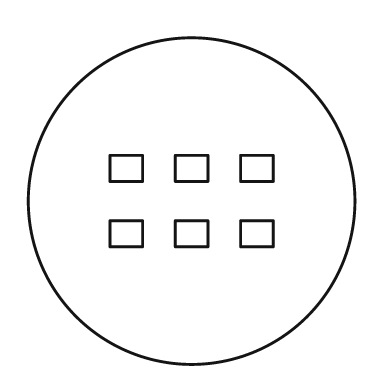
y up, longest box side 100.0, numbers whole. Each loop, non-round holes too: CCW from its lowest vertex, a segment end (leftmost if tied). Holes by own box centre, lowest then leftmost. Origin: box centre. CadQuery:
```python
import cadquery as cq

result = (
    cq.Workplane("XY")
    .moveTo(0.0, 0.0)
    .circle(50.0)
    .moveTo(-25.0, -14.0)
    .lineTo(-15.0, -14.0)
    .lineTo(-15.0, -6.0)
    .lineTo(-25.0, -6.0)
    .close()
    .moveTo(-5.0, -14.0)
    .lineTo(5.0, -14.0)
    .lineTo(5.0, -6.0)
    .lineTo(-5.0, -6.0)
    .close()
    .moveTo(15.0, -14.0)
    .lineTo(25.0, -14.0)
    .lineTo(25.0, -6.0)
    .lineTo(15.0, -6.0)
    .close()
    .moveTo(-25.0, 6.0)
    .lineTo(-15.0, 6.0)
    .lineTo(-15.0, 14.0)
    .lineTo(-25.0, 14.0)
    .close()
    .moveTo(-5.0, 6.0)
    .lineTo(5.0, 6.0)
    .lineTo(5.0, 14.0)
    .lineTo(-5.0, 14.0)
    .close()
    .moveTo(15.0, 6.0)
    .lineTo(25.0, 6.0)
    .lineTo(25.0, 14.0)
    .lineTo(15.0, 14.0)
    .close()
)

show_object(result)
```